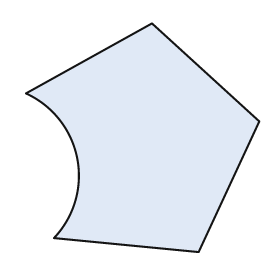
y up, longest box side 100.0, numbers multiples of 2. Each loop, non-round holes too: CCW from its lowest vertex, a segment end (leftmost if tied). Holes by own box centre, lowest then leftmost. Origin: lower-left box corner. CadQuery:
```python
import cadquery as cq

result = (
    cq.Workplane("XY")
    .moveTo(74.0, 0.0)
    .lineTo(100.0, 56.0)
    .lineTo(54.0, 98.0)
    .lineTo(0.0, 68.0)
    .threePointArc((22.0, 40.0), (12.0, 6.0))
    .close()
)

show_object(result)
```